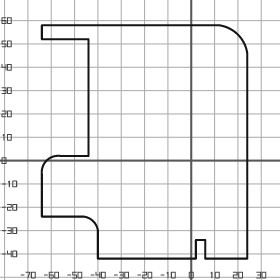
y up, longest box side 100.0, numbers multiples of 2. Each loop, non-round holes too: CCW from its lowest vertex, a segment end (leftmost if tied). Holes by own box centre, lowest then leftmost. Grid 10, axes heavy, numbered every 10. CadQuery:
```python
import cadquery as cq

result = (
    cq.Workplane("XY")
    .moveTo(-40.0, -42.0)
    .lineTo(2.0, -42.0)
    .lineTo(2.0, -34.0)
    .lineTo(6.0, -34.0)
    .lineTo(6.0, -42.0)
    .lineTo(24.0, -42.0)
    .lineTo(24.0, 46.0)
    .threePointArc((20.0, 54.0), (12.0, 58.0))
    .lineTo(-64.0, 58.0)
    .lineTo(-64.0, 52.0)
    .lineTo(-44.0, 52.0)
    .lineTo(-44.0, 2.0)
    .lineTo(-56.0, 2.0)
    .threePointArc((-62.0, 0.0), (-64.0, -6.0))
    .lineTo(-64.0, -24.0)
    .lineTo(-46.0, -24.0)
    .threePointArc((-42.0, -26.0), (-40.0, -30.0))
    .close()
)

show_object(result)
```